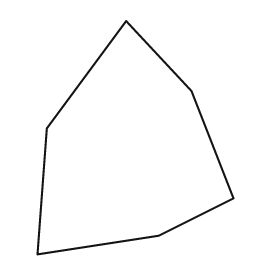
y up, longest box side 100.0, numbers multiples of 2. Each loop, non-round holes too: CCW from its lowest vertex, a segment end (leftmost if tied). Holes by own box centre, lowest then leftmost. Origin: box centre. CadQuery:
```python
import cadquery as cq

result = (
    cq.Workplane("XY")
    .moveTo(-42.0, -50.0)
    .lineTo(10.0, -42.0)
    .lineTo(42.0, -26.0)
    .lineTo(24.0, 20.0)
    .lineTo(-4.0, 50.0)
    .lineTo(-38.0, 4.0)
    .close()
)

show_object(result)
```